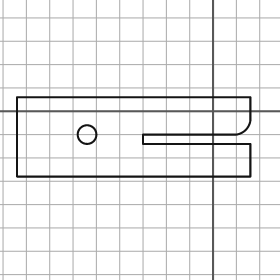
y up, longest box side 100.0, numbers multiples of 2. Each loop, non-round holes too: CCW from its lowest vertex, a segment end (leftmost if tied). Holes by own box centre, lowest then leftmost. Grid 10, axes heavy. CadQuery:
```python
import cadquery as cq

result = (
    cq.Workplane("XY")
    .moveTo(-84.0, -28.0)
    .lineTo(16.0, -28.0)
    .lineTo(16.0, -14.0)
    .lineTo(-30.0, -14.0)
    .lineTo(-30.0, -10.0)
    .lineTo(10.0, -10.0)
    .threePointArc((14.0, -8.0), (16.0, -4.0))
    .lineTo(16.0, 6.0)
    .lineTo(-84.0, 6.0)
    .close()
    .moveTo(-54.0, -10.0)
    .circle(4.0)
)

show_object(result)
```